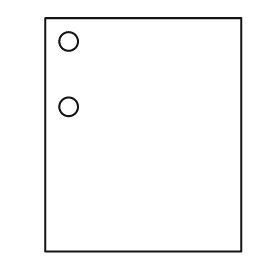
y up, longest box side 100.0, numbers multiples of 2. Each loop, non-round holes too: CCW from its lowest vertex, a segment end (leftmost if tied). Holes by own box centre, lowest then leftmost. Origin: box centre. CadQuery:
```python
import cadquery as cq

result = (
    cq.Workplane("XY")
    .moveTo(-42.0, -50.0)
    .lineTo(42.0, -50.0)
    .lineTo(42.0, 50.0)
    .lineTo(-42.0, 50.0)
    .close()
    .moveTo(-32.0, 12.0)
    .circle(4.0)
    .moveTo(-32.0, 40.0)
    .circle(4.0)
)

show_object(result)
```